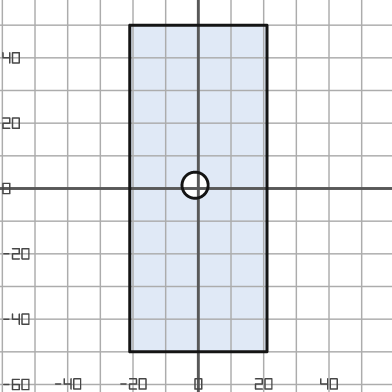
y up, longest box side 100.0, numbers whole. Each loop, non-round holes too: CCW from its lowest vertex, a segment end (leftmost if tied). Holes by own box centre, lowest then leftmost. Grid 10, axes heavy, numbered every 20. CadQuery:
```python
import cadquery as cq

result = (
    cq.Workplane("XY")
    .moveTo(-21.0, -50.0)
    .lineTo(21.0, -50.0)
    .lineTo(21.0, 50.0)
    .lineTo(-21.0, 50.0)
    .close()
    .moveTo(-1.0, 1.0)
    .circle(4.0)
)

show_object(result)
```